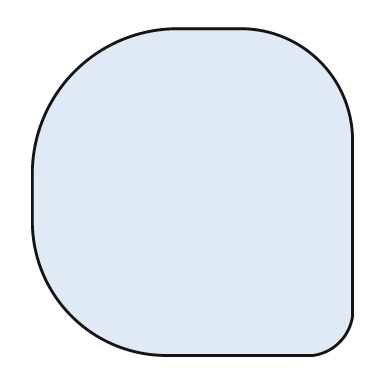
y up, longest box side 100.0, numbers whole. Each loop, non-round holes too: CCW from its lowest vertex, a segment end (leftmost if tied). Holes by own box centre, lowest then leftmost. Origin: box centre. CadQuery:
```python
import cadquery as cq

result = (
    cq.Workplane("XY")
    .moveTo(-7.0, -50.0)
    .lineTo(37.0, -50.0)
    .threePointArc((45.0, -46.0), (49.0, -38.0))
    .lineTo(49.0, 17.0)
    .threePointArc((39.0, 40.0), (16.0, 50.0))
    .lineTo(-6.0, 50.0)
    .threePointArc((-36.0, 37.0), (-49.0, 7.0))
    .lineTo(-49.0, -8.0)
    .threePointArc((-37.0, -38.0), (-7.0, -50.0))
    .close()
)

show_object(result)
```